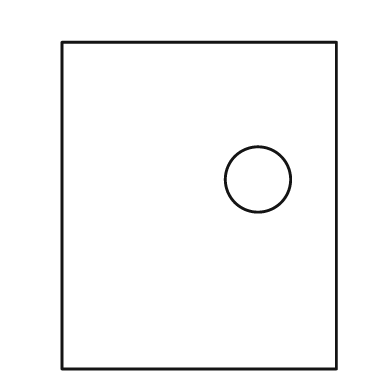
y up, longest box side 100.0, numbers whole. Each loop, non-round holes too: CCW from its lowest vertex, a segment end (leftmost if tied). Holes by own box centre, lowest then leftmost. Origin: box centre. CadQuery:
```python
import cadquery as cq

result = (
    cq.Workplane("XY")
    .moveTo(-42.0, -50.0)
    .lineTo(42.0, -50.0)
    .lineTo(42.0, 50.0)
    .lineTo(-42.0, 50.0)
    .close()
    .moveTo(18.0, 8.0)
    .circle(10.0)
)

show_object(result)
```